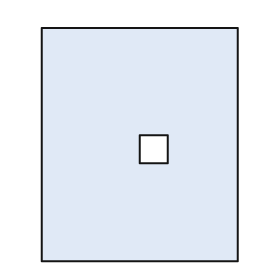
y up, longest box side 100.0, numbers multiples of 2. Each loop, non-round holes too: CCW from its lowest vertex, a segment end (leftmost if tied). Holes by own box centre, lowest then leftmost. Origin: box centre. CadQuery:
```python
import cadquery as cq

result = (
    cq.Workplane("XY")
    .moveTo(-42.0, -50.0)
    .lineTo(42.0, -50.0)
    .lineTo(42.0, 50.0)
    .lineTo(-42.0, 50.0)
    .close()
    .moveTo(0.0, -8.0)
    .lineTo(12.0, -8.0)
    .lineTo(12.0, 4.0)
    .lineTo(0.0, 4.0)
    .close()
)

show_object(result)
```